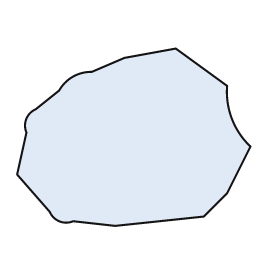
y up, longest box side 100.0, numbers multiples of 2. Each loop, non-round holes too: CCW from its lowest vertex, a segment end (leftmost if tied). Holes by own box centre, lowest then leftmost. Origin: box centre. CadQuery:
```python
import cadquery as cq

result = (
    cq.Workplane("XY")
    .moveTo(-8.0, -38.0)
    .lineTo(30.0, -34.0)
    .lineTo(40.0, -24.0)
    .lineTo(50.0, -4.0)
    .threePointArc((42.0, 8.0), (40.0, 22.0))
    .lineTo(18.0, 38.0)
    .lineTo(-4.0, 34.0)
    .lineTo(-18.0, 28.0)
    .threePointArc((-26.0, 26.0), (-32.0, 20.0))
    .lineTo(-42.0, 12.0)
    .threePointArc((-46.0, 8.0), (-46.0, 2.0))
    .lineTo(-50.0, -16.0)
    .lineTo(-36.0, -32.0)
    .threePointArc((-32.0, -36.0), (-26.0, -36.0))
    .close()
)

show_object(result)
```